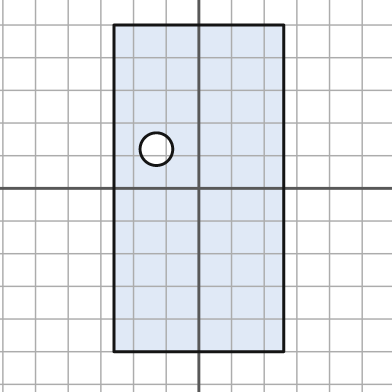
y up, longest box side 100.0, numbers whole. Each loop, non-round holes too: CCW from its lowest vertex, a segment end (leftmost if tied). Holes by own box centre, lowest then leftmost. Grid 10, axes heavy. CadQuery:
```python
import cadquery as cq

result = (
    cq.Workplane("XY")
    .moveTo(-26.0, -50.0)
    .lineTo(26.0, -50.0)
    .lineTo(26.0, 50.0)
    .lineTo(-26.0, 50.0)
    .close()
    .moveTo(-13.0, 12.0)
    .circle(5.0)
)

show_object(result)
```